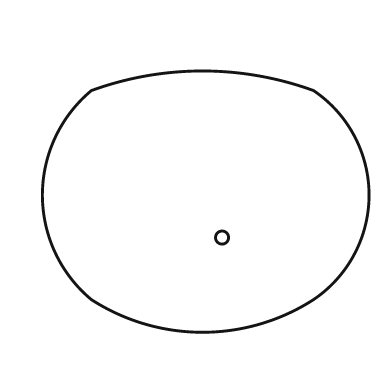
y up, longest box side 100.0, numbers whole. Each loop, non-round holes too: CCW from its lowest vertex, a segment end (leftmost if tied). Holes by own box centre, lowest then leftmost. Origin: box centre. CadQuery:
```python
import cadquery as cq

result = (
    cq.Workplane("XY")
    .moveTo(-35.0, -30.0)
    .threePointArc((-1.0, -40.0), (33.0, -30.0))
    .threePointArc((50.0, 2.0), (33.0, 34.0))
    .threePointArc((-1.0, 40.0), (-35.0, 34.0))
    .threePointArc((-50.0, 2.0), (-35.0, -30.0))
    .close()
    .moveTo(5.0, -11.0)
    .circle(2.0)
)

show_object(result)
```